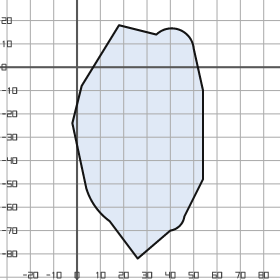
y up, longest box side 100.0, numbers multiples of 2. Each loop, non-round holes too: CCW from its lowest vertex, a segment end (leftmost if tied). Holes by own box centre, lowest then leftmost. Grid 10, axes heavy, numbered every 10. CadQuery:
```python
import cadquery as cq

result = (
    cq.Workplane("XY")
    .moveTo(26.0, -82.0)
    .lineTo(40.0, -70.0)
    .threePointArc((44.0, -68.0), (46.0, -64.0))
    .lineTo(54.0, -48.0)
    .lineTo(54.0, -10.0)
    .lineTo(50.0, 8.0)
    .threePointArc((44.0, 16.0), (34.0, 14.0))
    .lineTo(18.0, 18.0)
    .lineTo(2.0, -8.0)
    .lineTo(-2.0, -24.0)
    .lineTo(4.0, -52.0)
    .threePointArc((8.0, -60.0), (14.0, -66.0))
    .close()
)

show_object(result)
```